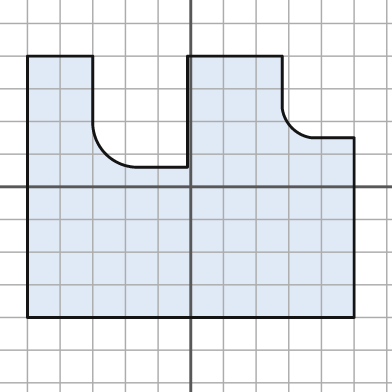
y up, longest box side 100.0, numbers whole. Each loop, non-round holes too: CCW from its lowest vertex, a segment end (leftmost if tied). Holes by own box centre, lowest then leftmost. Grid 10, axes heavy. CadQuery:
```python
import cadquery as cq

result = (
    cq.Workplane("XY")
    .moveTo(-50.0, -40.0)
    .lineTo(50.0, -40.0)
    .lineTo(50.0, 15.0)
    .lineTo(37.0, 15.0)
    .threePointArc((31.0, 18.0), (28.0, 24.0))
    .lineTo(28.0, 40.0)
    .lineTo(-1.0, 40.0)
    .lineTo(-1.0, 6.0)
    .lineTo(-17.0, 6.0)
    .threePointArc((-26.0, 10.0), (-30.0, 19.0))
    .lineTo(-30.0, 40.0)
    .lineTo(-50.0, 40.0)
    .close()
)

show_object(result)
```